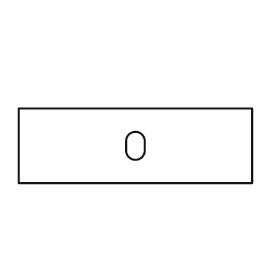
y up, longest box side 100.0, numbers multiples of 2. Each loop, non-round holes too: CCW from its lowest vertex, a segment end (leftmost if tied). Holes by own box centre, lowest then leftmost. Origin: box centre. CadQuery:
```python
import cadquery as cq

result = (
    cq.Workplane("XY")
    .moveTo(-50.0, -16.0)
    .lineTo(50.0, -16.0)
    .lineTo(50.0, 16.0)
    .lineTo(-50.0, 16.0)
    .close()
    .moveTo(-4.0, -2.0)
    .threePointArc((0.0, -6.0), (4.0, -2.0))
    .lineTo(4.0, 2.0)
    .threePointArc((0.0, 6.0), (-4.0, 2.0))
    .close()
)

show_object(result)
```